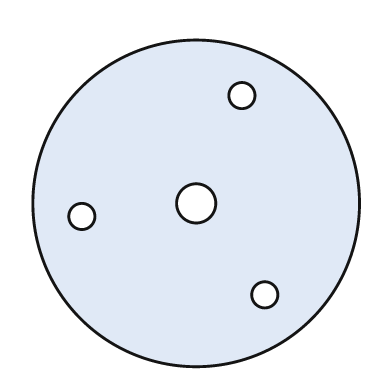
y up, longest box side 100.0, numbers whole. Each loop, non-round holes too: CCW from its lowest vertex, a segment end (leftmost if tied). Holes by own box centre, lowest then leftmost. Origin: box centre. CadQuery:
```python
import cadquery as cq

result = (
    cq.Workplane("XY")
    .moveTo(0.0, 0.0)
    .circle(50.0)
    .moveTo(21.0, -28.0)
    .circle(4.0)
    .moveTo(-35.0, -4.0)
    .circle(4.0)
    .moveTo(0.0, 0.0)
    .circle(6.0)
    .moveTo(14.0, 33.0)
    .circle(4.0)
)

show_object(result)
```